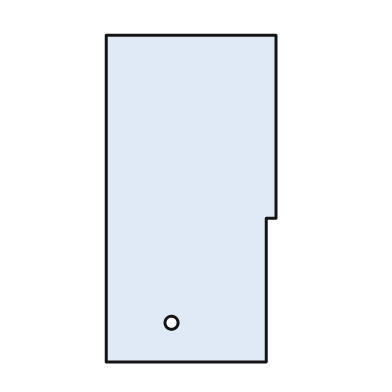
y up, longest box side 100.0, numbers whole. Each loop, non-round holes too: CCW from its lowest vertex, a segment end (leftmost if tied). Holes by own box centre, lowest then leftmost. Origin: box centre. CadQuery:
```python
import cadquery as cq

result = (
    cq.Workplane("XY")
    .moveTo(-26.0, -50.0)
    .lineTo(23.0, -50.0)
    .lineTo(23.0, -6.0)
    .lineTo(26.0, -6.0)
    .lineTo(26.0, 50.0)
    .lineTo(-26.0, 50.0)
    .close()
    .moveTo(-6.0, -38.0)
    .circle(2.0)
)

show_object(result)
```